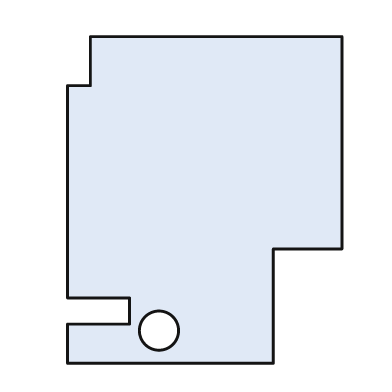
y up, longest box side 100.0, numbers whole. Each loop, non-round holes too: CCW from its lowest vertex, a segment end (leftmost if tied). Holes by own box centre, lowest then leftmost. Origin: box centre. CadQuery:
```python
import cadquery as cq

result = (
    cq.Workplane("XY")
    .moveTo(-42.0, -50.0)
    .lineTo(21.0, -50.0)
    .lineTo(21.0, -15.0)
    .lineTo(42.0, -15.0)
    .lineTo(42.0, 50.0)
    .lineTo(-35.0, 50.0)
    .lineTo(-35.0, 35.0)
    .lineTo(-42.0, 35.0)
    .lineTo(-42.0, -30.0)
    .lineTo(-23.0, -30.0)
    .lineTo(-23.0, -38.0)
    .lineTo(-42.0, -38.0)
    .close()
    .moveTo(-14.0, -40.0)
    .circle(6.0)
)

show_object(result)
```